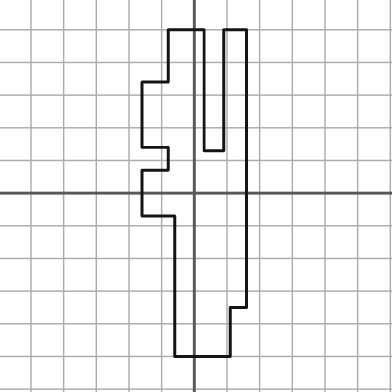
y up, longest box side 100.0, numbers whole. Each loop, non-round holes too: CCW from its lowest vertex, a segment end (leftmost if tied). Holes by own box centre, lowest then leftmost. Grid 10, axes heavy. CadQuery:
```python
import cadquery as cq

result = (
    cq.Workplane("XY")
    .moveTo(-6.0, -50.0)
    .lineTo(11.0, -50.0)
    .lineTo(11.0, -35.0)
    .lineTo(16.0, -35.0)
    .lineTo(16.0, 50.0)
    .lineTo(9.0, 50.0)
    .lineTo(9.0, 13.0)
    .lineTo(3.0, 13.0)
    .lineTo(3.0, 50.0)
    .lineTo(-8.0, 50.0)
    .lineTo(-8.0, 34.0)
    .lineTo(-16.0, 34.0)
    .lineTo(-16.0, 14.0)
    .lineTo(-8.0, 14.0)
    .lineTo(-8.0, 7.0)
    .lineTo(-16.0, 7.0)
    .lineTo(-16.0, -7.0)
    .lineTo(-6.0, -7.0)
    .close()
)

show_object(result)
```